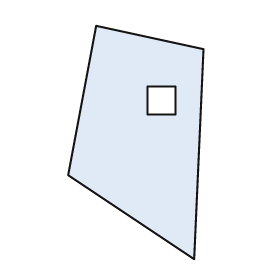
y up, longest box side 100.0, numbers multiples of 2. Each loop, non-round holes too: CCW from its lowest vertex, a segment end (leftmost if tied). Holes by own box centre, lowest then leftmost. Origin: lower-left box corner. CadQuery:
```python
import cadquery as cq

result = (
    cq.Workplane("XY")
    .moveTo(54.0, 0.0)
    .lineTo(58.0, 90.0)
    .lineTo(12.0, 100.0)
    .lineTo(0.0, 36.0)
    .close()
    .moveTo(34.0, 62.0)
    .lineTo(46.0, 62.0)
    .lineTo(46.0, 74.0)
    .lineTo(34.0, 74.0)
    .close()
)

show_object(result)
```